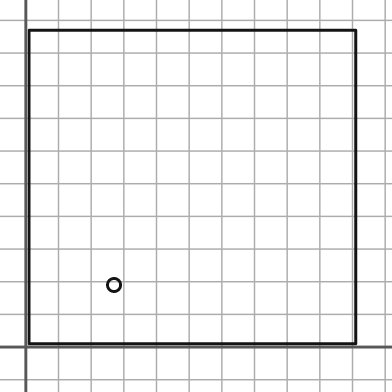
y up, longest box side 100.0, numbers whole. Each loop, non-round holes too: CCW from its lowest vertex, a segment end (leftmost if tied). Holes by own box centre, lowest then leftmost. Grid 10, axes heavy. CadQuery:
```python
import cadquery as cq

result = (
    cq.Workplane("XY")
    .moveTo(1.0, 1.0)
    .lineTo(101.0, 1.0)
    .lineTo(101.0, 97.0)
    .lineTo(1.0, 97.0)
    .close()
    .moveTo(27.0, 19.0)
    .circle(2.0)
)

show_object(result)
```